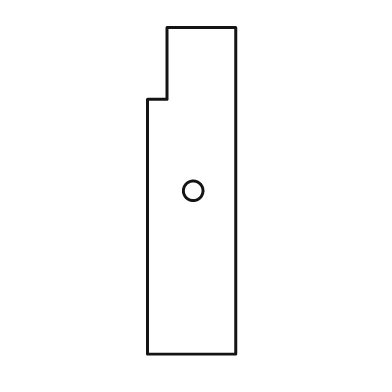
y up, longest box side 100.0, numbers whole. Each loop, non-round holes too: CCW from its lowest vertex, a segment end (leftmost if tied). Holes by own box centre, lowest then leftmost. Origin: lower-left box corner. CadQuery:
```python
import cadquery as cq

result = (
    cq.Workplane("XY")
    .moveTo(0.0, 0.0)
    .lineTo(27.0, 0.0)
    .lineTo(27.0, 100.0)
    .lineTo(6.0, 100.0)
    .lineTo(6.0, 78.0)
    .lineTo(0.0, 78.0)
    .close()
    .moveTo(14.0, 50.0)
    .circle(3.0)
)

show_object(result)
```